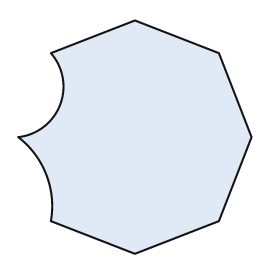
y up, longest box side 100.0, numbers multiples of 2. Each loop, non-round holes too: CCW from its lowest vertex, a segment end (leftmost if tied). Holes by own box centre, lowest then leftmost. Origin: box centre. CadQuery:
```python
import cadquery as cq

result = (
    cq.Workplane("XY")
    .moveTo(0.0, -50.0)
    .lineTo(36.0, -36.0)
    .lineTo(50.0, 0.0)
    .lineTo(36.0, 36.0)
    .lineTo(0.0, 50.0)
    .lineTo(-36.0, 36.0)
    .threePointArc((-32.0, 14.0), (-50.0, 0.0))
    .threePointArc((-38.0, -16.0), (-36.0, -36.0))
    .close()
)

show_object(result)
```